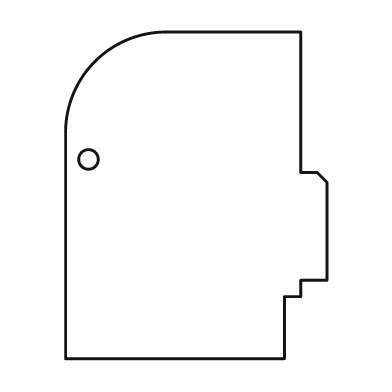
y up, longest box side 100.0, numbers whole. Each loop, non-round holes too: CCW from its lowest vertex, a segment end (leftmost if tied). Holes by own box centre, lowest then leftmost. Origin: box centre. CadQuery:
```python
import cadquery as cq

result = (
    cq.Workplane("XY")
    .moveTo(-40.0, -50.0)
    .lineTo(27.0, -50.0)
    .lineTo(27.0, -31.0)
    .lineTo(32.0, -31.0)
    .lineTo(32.0, -26.0)
    .lineTo(40.0, -26.0)
    .lineTo(40.0, 4.0)
    .lineTo(37.0, 7.0)
    .lineTo(32.0, 7.0)
    .lineTo(32.0, 50.0)
    .lineTo(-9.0, 50.0)
    .threePointArc((-31.0, 41.0), (-40.0, 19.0))
    .close()
    .moveTo(-33.0, 11.0)
    .circle(3.0)
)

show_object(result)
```